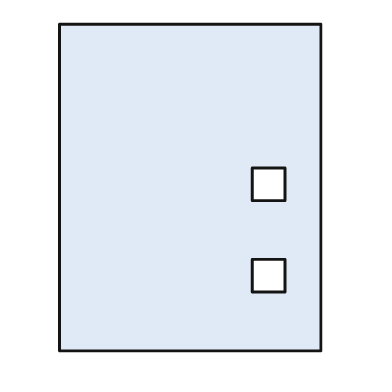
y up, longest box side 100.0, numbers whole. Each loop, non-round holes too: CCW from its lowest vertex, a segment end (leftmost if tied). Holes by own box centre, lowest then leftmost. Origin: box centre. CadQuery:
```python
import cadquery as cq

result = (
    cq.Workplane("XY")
    .moveTo(-40.0, -50.0)
    .lineTo(40.0, -50.0)
    .lineTo(40.0, 50.0)
    .lineTo(-40.0, 50.0)
    .close()
    .moveTo(19.0, -32.0)
    .lineTo(29.0, -32.0)
    .lineTo(29.0, -22.0)
    .lineTo(19.0, -22.0)
    .close()
    .moveTo(19.0, -4.0)
    .lineTo(29.0, -4.0)
    .lineTo(29.0, 6.0)
    .lineTo(19.0, 6.0)
    .close()
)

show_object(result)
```